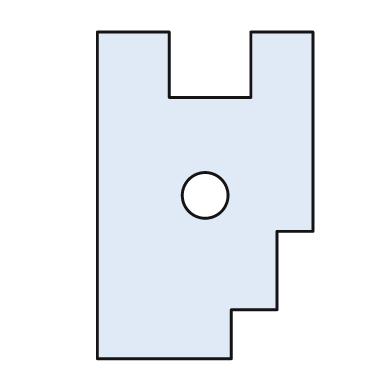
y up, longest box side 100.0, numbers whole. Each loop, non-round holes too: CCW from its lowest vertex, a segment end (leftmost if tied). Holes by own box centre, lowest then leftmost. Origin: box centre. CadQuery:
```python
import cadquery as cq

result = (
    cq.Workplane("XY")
    .moveTo(-33.0, -50.0)
    .lineTo(8.0, -50.0)
    .lineTo(8.0, -35.0)
    .lineTo(22.0, -35.0)
    .lineTo(22.0, -11.0)
    .lineTo(33.0, -11.0)
    .lineTo(33.0, 50.0)
    .lineTo(14.0, 50.0)
    .lineTo(14.0, 30.0)
    .lineTo(-11.0, 30.0)
    .lineTo(-11.0, 50.0)
    .lineTo(-33.0, 50.0)
    .close()
    .moveTo(0.0, 0.0)
    .circle(7.0)
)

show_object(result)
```